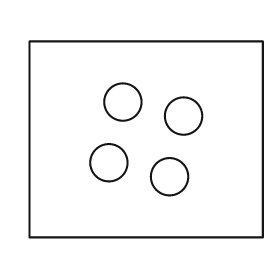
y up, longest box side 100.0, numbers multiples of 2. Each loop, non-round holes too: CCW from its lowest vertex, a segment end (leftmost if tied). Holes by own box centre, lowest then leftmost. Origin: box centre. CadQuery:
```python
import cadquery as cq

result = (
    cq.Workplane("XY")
    .moveTo(-50.0, -42.0)
    .lineTo(50.0, -42.0)
    .lineTo(50.0, 42.0)
    .lineTo(-50.0, 42.0)
    .close()
    .moveTo(10.0, -16.0)
    .circle(8.0)
    .moveTo(-16.0, -10.0)
    .circle(8.0)
    .moveTo(16.0, 10.0)
    .circle(8.0)
    .moveTo(-10.0, 16.0)
    .circle(8.0)
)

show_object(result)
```